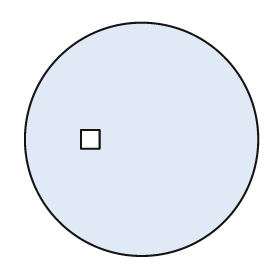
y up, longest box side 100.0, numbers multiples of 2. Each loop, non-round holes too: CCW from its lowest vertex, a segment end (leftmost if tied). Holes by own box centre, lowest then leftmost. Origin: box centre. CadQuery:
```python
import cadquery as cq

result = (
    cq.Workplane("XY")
    .moveTo(0.0, 0.0)
    .circle(50.0)
    .moveTo(-26.0, -4.0)
    .lineTo(-18.0, -4.0)
    .lineTo(-18.0, 4.0)
    .lineTo(-26.0, 4.0)
    .close()
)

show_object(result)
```